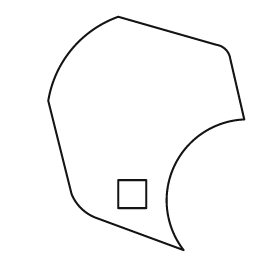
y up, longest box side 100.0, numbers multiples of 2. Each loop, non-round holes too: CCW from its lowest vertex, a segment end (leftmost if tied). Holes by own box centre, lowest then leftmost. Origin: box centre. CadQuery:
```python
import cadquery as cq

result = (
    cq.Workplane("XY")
    .moveTo(16.0, -50.0)
    .threePointArc((12.0, -14.0), (42.0, 6.0))
    .lineTo(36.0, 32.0)
    .threePointArc((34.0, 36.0), (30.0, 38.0))
    .lineTo(-12.0, 50.0)
    .threePointArc((-32.0, 36.0), (-42.0, 14.0))
    .lineTo(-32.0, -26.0)
    .threePointArc((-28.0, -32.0), (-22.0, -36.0))
    .close()
    .moveTo(-12.0, -32.0)
    .lineTo(0.0, -32.0)
    .lineTo(0.0, -20.0)
    .lineTo(-12.0, -20.0)
    .close()
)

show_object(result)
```